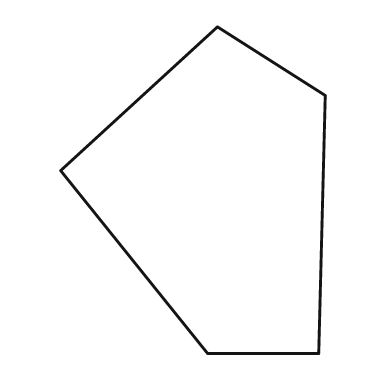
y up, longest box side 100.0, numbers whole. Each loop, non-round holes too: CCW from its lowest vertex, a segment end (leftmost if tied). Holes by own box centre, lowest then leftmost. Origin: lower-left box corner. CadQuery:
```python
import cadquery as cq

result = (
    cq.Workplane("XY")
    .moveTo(45.0, 0.0)
    .lineTo(79.0, 0.0)
    .lineTo(81.0, 79.0)
    .lineTo(48.0, 100.0)
    .lineTo(0.0, 56.0)
    .close()
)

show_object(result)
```